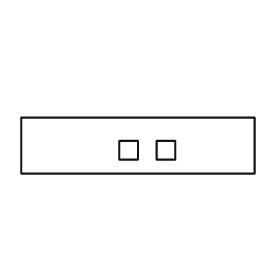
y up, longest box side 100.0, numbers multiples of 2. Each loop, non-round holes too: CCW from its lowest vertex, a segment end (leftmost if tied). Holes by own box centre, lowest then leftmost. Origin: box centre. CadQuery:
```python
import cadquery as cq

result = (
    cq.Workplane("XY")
    .moveTo(-50.0, -12.0)
    .lineTo(50.0, -12.0)
    .lineTo(50.0, 12.0)
    .lineTo(-50.0, 12.0)
    .close()
    .moveTo(-8.0, -6.0)
    .lineTo(0.0, -6.0)
    .lineTo(0.0, 2.0)
    .lineTo(-8.0, 2.0)
    .close()
    .moveTo(8.0, -6.0)
    .lineTo(16.0, -6.0)
    .lineTo(16.0, 2.0)
    .lineTo(8.0, 2.0)
    .close()
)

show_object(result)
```